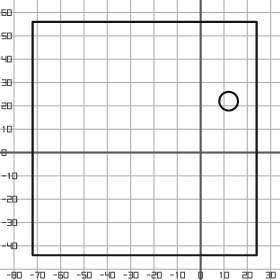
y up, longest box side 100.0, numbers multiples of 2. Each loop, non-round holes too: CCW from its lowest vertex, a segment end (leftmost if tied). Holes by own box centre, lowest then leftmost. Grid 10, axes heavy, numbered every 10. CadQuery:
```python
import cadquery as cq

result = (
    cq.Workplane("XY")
    .moveTo(-72.0, -44.0)
    .lineTo(24.0, -44.0)
    .lineTo(24.0, 56.0)
    .lineTo(-72.0, 56.0)
    .close()
    .moveTo(12.0, 22.0)
    .circle(4.0)
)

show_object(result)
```